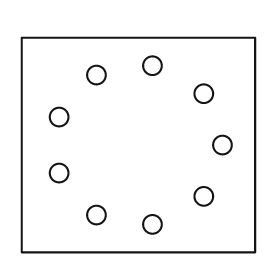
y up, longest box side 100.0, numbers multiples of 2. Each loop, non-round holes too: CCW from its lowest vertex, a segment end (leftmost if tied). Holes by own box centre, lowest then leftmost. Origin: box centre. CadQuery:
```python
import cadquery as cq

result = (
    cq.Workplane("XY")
    .moveTo(-50.0, -46.0)
    .lineTo(50.0, -46.0)
    .lineTo(50.0, 46.0)
    .lineTo(-50.0, 46.0)
    .close()
    .moveTo(6.0, -34.0)
    .circle(4.0)
    .moveTo(-18.0, -30.0)
    .circle(4.0)
    .moveTo(28.0, -22.0)
    .circle(4.0)
    .moveTo(-34.0, -12.0)
    .circle(4.0)
    .moveTo(36.0, 0.0)
    .circle(4.0)
    .moveTo(-34.0, 12.0)
    .circle(4.0)
    .moveTo(28.0, 22.0)
    .circle(4.0)
    .moveTo(-18.0, 30.0)
    .circle(4.0)
    .moveTo(6.0, 34.0)
    .circle(4.0)
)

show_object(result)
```